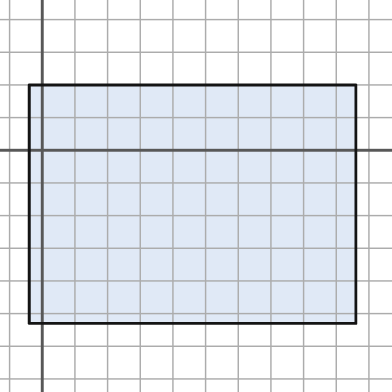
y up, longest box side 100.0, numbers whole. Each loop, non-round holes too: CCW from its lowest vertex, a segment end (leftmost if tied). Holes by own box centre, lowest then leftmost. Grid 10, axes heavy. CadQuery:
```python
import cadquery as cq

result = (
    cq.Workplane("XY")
    .moveTo(-4.0, -53.0)
    .lineTo(96.0, -53.0)
    .lineTo(96.0, 20.0)
    .lineTo(-4.0, 20.0)
    .close()
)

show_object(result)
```